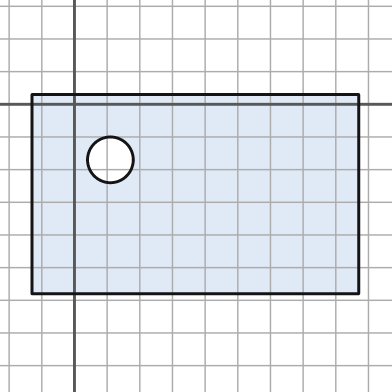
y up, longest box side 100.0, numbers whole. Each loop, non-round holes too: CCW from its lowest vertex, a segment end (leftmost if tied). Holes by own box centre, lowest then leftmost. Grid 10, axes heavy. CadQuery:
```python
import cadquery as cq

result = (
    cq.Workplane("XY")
    .moveTo(-13.0, -58.0)
    .lineTo(87.0, -58.0)
    .lineTo(87.0, 3.0)
    .lineTo(-13.0, 3.0)
    .close()
    .moveTo(11.0, -17.0)
    .circle(7.0)
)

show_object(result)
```